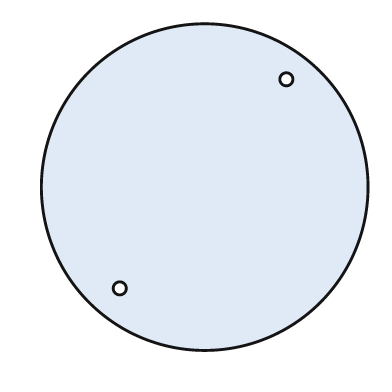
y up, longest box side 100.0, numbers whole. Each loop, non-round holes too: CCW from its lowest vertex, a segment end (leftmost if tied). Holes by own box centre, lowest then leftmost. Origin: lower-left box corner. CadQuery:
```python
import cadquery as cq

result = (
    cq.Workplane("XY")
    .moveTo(50.0, 50.0)
    .circle(50.0)
    .moveTo(24.0, 19.0)
    .circle(2.0)
    .moveTo(75.0, 83.0)
    .circle(2.0)
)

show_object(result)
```